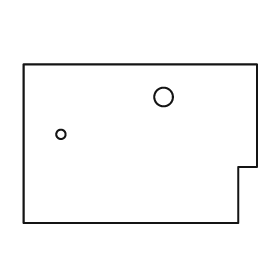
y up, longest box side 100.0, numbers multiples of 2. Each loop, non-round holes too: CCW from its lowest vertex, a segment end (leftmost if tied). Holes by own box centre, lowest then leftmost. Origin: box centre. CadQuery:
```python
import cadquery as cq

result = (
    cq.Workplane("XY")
    .moveTo(-50.0, -34.0)
    .lineTo(42.0, -34.0)
    .lineTo(42.0, -10.0)
    .lineTo(50.0, -10.0)
    .lineTo(50.0, 34.0)
    .lineTo(-50.0, 34.0)
    .close()
    .moveTo(-34.0, 4.0)
    .circle(2.0)
    .moveTo(10.0, 20.0)
    .circle(4.0)
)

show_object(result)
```